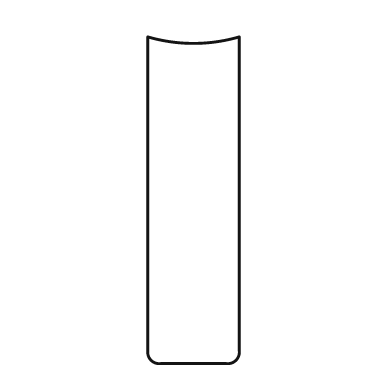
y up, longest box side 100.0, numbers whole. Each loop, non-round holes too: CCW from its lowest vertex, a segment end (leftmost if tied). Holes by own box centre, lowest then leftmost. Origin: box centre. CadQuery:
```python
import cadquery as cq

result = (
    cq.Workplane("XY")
    .moveTo(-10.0, -50.0)
    .lineTo(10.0, -50.0)
    .threePointArc((13.0, -49.0), (14.0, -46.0))
    .lineTo(14.0, 50.0)
    .threePointArc((0.0, 48.0), (-14.0, 50.0))
    .lineTo(-14.0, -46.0)
    .threePointArc((-13.0, -49.0), (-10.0, -50.0))
    .close()
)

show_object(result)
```